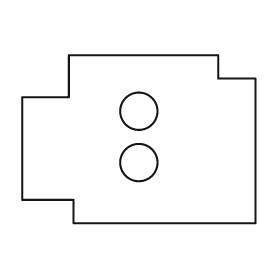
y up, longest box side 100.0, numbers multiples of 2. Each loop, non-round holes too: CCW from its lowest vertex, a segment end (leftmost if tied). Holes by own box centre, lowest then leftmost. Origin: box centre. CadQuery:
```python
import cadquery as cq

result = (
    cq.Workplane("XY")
    .moveTo(-28.0, -36.0)
    .lineTo(50.0, -36.0)
    .lineTo(50.0, 26.0)
    .lineTo(34.0, 26.0)
    .lineTo(34.0, 36.0)
    .lineTo(-30.0, 36.0)
    .lineTo(-30.0, 18.0)
    .lineTo(-50.0, 18.0)
    .lineTo(-50.0, -26.0)
    .lineTo(-28.0, -26.0)
    .close()
    .moveTo(0.0, -10.0)
    .circle(8.0)
    .moveTo(0.0, 12.0)
    .circle(8.0)
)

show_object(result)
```